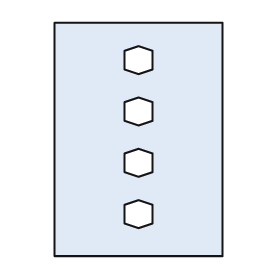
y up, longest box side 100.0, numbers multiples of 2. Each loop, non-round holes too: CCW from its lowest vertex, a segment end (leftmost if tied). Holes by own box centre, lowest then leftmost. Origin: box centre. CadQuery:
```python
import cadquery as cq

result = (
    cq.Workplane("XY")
    .moveTo(-36.0, -50.0)
    .lineTo(36.0, -50.0)
    .lineTo(36.0, 50.0)
    .lineTo(-36.0, 50.0)
    .close()
    .moveTo(0.0, -38.0)
    .lineTo(6.0, -36.0)
    .lineTo(6.0, -28.0)
    .lineTo(0.0, -26.0)
    .lineTo(-6.0, -28.0)
    .lineTo(-6.0, -36.0)
    .close()
    .moveTo(0.0, -16.0)
    .lineTo(6.0, -14.0)
    .lineTo(6.0, -6.0)
    .lineTo(0.0, -4.0)
    .lineTo(-6.0, -6.0)
    .lineTo(-6.0, -14.0)
    .close()
    .moveTo(0.0, 6.0)
    .lineTo(6.0, 8.0)
    .lineTo(6.0, 16.0)
    .lineTo(0.0, 18.0)
    .lineTo(-6.0, 16.0)
    .lineTo(-6.0, 8.0)
    .close()
    .moveTo(0.0, 28.0)
    .lineTo(6.0, 30.0)
    .lineTo(6.0, 38.0)
    .lineTo(0.0, 40.0)
    .lineTo(-6.0, 38.0)
    .lineTo(-6.0, 30.0)
    .close()
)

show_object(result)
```